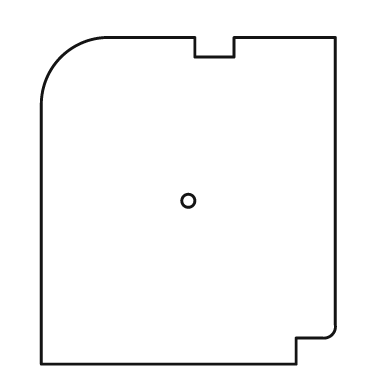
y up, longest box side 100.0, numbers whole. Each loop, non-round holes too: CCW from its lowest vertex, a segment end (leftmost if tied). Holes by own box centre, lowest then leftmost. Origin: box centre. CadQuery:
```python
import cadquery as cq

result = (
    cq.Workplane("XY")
    .moveTo(-45.0, -50.0)
    .lineTo(33.0, -50.0)
    .lineTo(33.0, -42.0)
    .lineTo(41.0, -42.0)
    .threePointArc((44.0, -41.0), (45.0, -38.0))
    .lineTo(45.0, 50.0)
    .lineTo(14.0, 50.0)
    .lineTo(14.0, 44.0)
    .lineTo(2.0, 44.0)
    .lineTo(2.0, 50.0)
    .lineTo(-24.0, 50.0)
    .threePointArc((-39.0, 44.0), (-45.0, 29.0))
    .close()
    .moveTo(0.0, 0.0)
    .circle(2.0)
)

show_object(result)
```